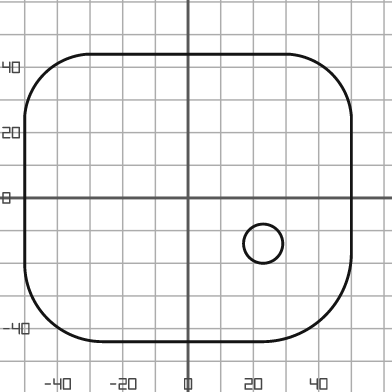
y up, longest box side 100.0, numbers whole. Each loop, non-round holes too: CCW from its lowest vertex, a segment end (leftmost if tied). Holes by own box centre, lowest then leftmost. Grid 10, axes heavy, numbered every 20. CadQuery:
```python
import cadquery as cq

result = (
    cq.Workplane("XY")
    .moveTo(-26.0, -44.0)
    .lineTo(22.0, -44.0)
    .threePointArc((42.0, -36.0), (50.0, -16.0))
    .lineTo(50.0, 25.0)
    .threePointArc((44.0, 38.0), (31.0, 44.0))
    .lineTo(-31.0, 44.0)
    .threePointArc((-44.0, 38.0), (-50.0, 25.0))
    .lineTo(-50.0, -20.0)
    .threePointArc((-43.0, -37.0), (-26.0, -44.0))
    .close()
    .moveTo(23.0, -14.0)
    .circle(6.0)
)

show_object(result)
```